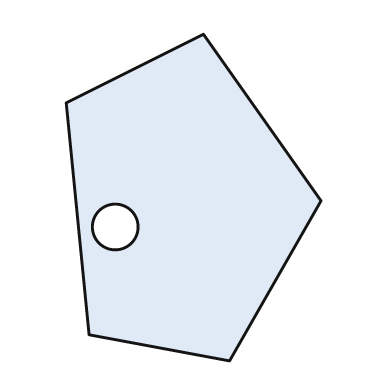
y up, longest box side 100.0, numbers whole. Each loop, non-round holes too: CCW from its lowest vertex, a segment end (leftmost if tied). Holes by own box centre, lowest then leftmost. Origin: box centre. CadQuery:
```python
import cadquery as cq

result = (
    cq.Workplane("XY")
    .moveTo(11.0, -50.0)
    .lineTo(39.0, -1.0)
    .lineTo(3.0, 50.0)
    .lineTo(-39.0, 29.0)
    .lineTo(-32.0, -42.0)
    .close()
    .moveTo(-24.0, -9.0)
    .circle(7.0)
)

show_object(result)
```